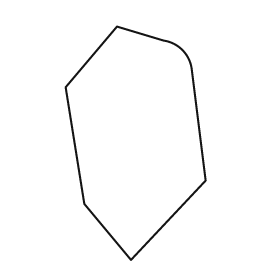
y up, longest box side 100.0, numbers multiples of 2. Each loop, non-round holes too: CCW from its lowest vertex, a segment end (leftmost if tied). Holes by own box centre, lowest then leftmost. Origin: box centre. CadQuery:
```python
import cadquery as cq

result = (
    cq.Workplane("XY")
    .moveTo(-2.0, -50.0)
    .lineTo(30.0, -16.0)
    .lineTo(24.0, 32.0)
    .threePointArc((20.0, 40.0), (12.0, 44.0))
    .lineTo(-8.0, 50.0)
    .lineTo(-30.0, 24.0)
    .lineTo(-22.0, -26.0)
    .close()
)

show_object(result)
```